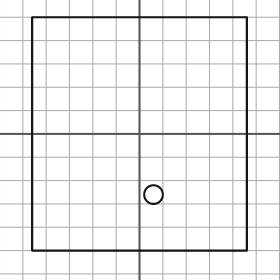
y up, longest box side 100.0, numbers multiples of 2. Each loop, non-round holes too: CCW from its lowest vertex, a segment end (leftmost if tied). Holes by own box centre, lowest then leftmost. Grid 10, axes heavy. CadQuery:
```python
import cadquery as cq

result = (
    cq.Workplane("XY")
    .moveTo(-46.0, -50.0)
    .lineTo(46.0, -50.0)
    .lineTo(46.0, 50.0)
    .lineTo(-46.0, 50.0)
    .close()
    .moveTo(6.0, -26.0)
    .circle(4.0)
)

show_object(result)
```